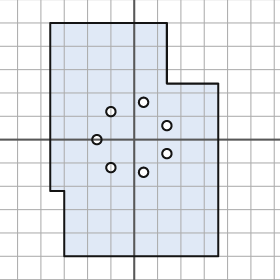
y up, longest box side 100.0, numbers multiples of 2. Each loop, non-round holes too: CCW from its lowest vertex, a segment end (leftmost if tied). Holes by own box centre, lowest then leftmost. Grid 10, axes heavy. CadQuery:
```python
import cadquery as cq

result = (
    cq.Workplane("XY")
    .moveTo(-30.0, -50.0)
    .lineTo(36.0, -50.0)
    .lineTo(36.0, 24.0)
    .lineTo(14.0, 24.0)
    .lineTo(14.0, 50.0)
    .lineTo(-36.0, 50.0)
    .lineTo(-36.0, -22.0)
    .lineTo(-30.0, -22.0)
    .close()
    .moveTo(4.0, -14.0)
    .circle(2.0)
    .moveTo(-10.0, -12.0)
    .circle(2.0)
    .moveTo(14.0, -6.0)
    .circle(2.0)
    .moveTo(-16.0, 0.0)
    .circle(2.0)
    .moveTo(14.0, 6.0)
    .circle(2.0)
    .moveTo(-10.0, 12.0)
    .circle(2.0)
    .moveTo(4.0, 16.0)
    .circle(2.0)
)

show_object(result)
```